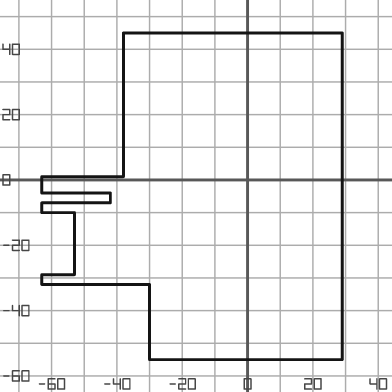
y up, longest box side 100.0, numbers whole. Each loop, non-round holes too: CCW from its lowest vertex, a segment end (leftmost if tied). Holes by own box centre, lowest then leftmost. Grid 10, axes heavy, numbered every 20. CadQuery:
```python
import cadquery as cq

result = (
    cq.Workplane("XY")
    .moveTo(-30.0, -55.0)
    .lineTo(29.0, -55.0)
    .lineTo(29.0, 45.0)
    .lineTo(-38.0, 45.0)
    .lineTo(-38.0, 1.0)
    .lineTo(-63.0, 1.0)
    .lineTo(-63.0, -4.0)
    .lineTo(-42.0, -4.0)
    .lineTo(-42.0, -7.0)
    .lineTo(-63.0, -7.0)
    .lineTo(-63.0, -10.0)
    .lineTo(-53.0, -10.0)
    .lineTo(-53.0, -29.0)
    .lineTo(-63.0, -29.0)
    .lineTo(-63.0, -32.0)
    .lineTo(-30.0, -32.0)
    .close()
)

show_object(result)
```